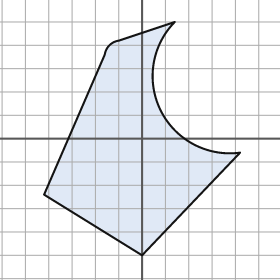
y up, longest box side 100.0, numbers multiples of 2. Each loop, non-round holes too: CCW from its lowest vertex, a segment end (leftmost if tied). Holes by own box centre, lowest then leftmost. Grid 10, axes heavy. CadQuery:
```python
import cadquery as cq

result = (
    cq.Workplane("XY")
    .moveTo(0.0, -50.0)
    .lineTo(42.0, -6.0)
    .threePointArc((8.0, 12.0), (14.0, 50.0))
    .lineTo(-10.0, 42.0)
    .threePointArc((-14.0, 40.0), (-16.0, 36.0))
    .lineTo(-42.0, -24.0)
    .close()
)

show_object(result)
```